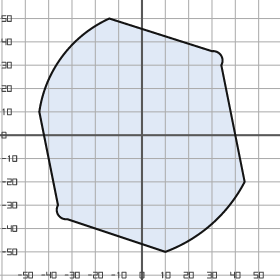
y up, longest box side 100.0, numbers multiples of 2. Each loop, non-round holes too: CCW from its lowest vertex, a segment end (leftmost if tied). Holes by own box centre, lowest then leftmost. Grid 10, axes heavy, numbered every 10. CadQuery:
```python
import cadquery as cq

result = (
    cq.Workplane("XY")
    .moveTo(10.0, -50.0)
    .threePointArc((30.0, -38.0), (44.0, -20.0))
    .lineTo(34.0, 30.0)
    .threePointArc((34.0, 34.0), (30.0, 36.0))
    .lineTo(-14.0, 50.0)
    .threePointArc((-34.0, 34.0), (-44.0, 10.0))
    .lineTo(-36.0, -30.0)
    .threePointArc((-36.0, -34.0), (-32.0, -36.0))
    .close()
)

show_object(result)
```